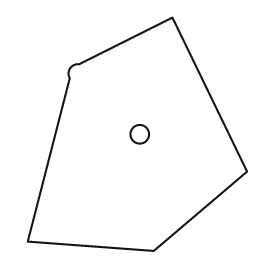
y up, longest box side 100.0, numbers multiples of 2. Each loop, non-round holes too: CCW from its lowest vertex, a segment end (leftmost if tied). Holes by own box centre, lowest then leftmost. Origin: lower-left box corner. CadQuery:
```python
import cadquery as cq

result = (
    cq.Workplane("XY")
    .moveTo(54.0, 0.0)
    .lineTo(94.0, 34.0)
    .lineTo(62.0, 100.0)
    .lineTo(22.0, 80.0)
    .threePointArc((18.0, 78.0), (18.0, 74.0))
    .lineTo(0.0, 4.0)
    .close()
    .moveTo(48.0, 50.0)
    .circle(4.0)
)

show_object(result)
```